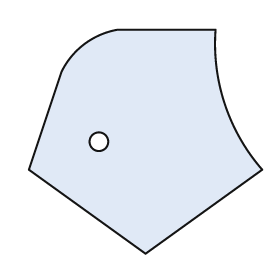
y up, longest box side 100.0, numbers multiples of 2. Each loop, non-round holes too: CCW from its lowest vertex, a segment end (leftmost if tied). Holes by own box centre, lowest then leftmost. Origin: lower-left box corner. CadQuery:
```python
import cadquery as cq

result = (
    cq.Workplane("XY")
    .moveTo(50.0, 0.0)
    .lineTo(100.0, 36.0)
    .threePointArc((84.0, 64.0), (80.0, 96.0))
    .lineTo(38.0, 96.0)
    .threePointArc((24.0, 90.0), (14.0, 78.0))
    .lineTo(0.0, 36.0)
    .close()
    .moveTo(30.0, 48.0)
    .circle(4.0)
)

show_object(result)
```